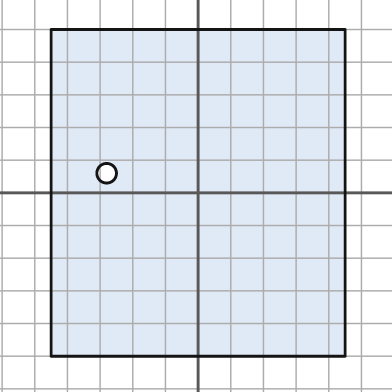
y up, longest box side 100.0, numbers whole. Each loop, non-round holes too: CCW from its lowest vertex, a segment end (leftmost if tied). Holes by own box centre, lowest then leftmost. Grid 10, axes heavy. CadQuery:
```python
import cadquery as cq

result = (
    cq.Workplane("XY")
    .moveTo(-45.0, -50.0)
    .lineTo(45.0, -50.0)
    .lineTo(45.0, 50.0)
    .lineTo(-45.0, 50.0)
    .close()
    .moveTo(-28.0, 6.0)
    .circle(3.0)
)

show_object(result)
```